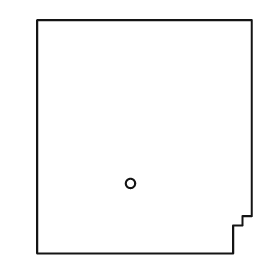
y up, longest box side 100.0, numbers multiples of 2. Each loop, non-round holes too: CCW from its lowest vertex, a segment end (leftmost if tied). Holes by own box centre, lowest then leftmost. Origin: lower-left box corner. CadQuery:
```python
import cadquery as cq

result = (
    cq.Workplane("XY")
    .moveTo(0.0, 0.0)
    .lineTo(84.0, 0.0)
    .lineTo(84.0, 12.0)
    .lineTo(88.0, 12.0)
    .lineTo(88.0, 16.0)
    .lineTo(92.0, 16.0)
    .lineTo(92.0, 100.0)
    .lineTo(0.0, 100.0)
    .close()
    .moveTo(40.0, 30.0)
    .circle(2.0)
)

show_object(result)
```